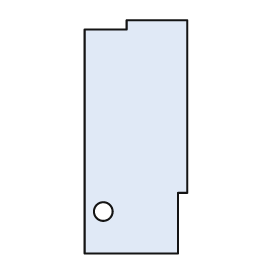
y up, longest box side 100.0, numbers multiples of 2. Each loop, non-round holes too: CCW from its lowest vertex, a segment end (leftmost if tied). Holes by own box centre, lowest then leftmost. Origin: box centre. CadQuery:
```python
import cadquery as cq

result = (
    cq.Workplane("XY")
    .moveTo(-22.0, -50.0)
    .lineTo(18.0, -50.0)
    .lineTo(18.0, -24.0)
    .lineTo(22.0, -24.0)
    .lineTo(22.0, 50.0)
    .lineTo(-4.0, 50.0)
    .lineTo(-4.0, 46.0)
    .lineTo(-22.0, 46.0)
    .close()
    .moveTo(-14.0, -32.0)
    .circle(4.0)
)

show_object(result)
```